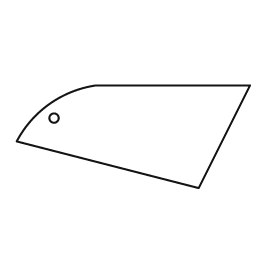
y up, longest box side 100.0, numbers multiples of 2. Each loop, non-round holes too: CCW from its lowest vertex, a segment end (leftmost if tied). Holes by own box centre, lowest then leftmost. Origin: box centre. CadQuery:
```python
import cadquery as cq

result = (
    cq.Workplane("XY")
    .moveTo(28.0, -22.0)
    .lineTo(50.0, 22.0)
    .lineTo(-16.0, 22.0)
    .threePointArc((-36.0, 14.0), (-50.0, -2.0))
    .close()
    .moveTo(-34.0, 8.0)
    .circle(2.0)
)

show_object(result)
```